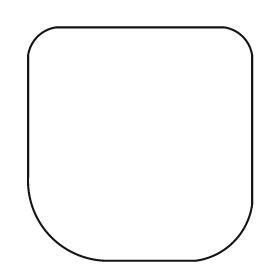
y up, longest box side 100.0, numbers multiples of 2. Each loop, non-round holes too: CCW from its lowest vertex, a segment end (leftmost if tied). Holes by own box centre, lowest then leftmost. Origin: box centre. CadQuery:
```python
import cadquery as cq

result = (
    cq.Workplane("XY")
    .moveTo(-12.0, -50.0)
    .lineTo(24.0, -50.0)
    .threePointArc((40.0, -42.0), (48.0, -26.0))
    .lineTo(48.0, 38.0)
    .threePointArc((44.0, 46.0), (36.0, 50.0))
    .lineTo(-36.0, 50.0)
    .threePointArc((-44.0, 46.0), (-48.0, 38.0))
    .lineTo(-48.0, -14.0)
    .threePointArc((-38.0, -40.0), (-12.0, -50.0))
    .close()
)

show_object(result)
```